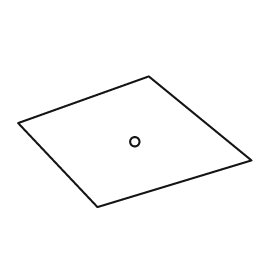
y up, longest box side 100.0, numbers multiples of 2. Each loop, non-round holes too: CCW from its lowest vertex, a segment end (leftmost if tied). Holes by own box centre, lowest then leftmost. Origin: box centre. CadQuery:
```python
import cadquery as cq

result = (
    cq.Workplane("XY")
    .moveTo(-16.0, -28.0)
    .lineTo(50.0, -8.0)
    .lineTo(6.0, 28.0)
    .lineTo(-50.0, 8.0)
    .close()
    .moveTo(0.0, 0.0)
    .circle(2.0)
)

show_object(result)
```